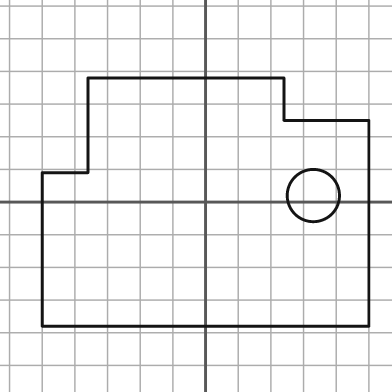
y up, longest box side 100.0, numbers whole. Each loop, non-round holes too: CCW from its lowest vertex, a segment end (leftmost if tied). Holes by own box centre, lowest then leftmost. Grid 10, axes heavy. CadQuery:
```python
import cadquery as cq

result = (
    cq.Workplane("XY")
    .moveTo(-50.0, -38.0)
    .lineTo(50.0, -38.0)
    .lineTo(50.0, 25.0)
    .lineTo(24.0, 25.0)
    .lineTo(24.0, 38.0)
    .lineTo(-36.0, 38.0)
    .lineTo(-36.0, 9.0)
    .lineTo(-50.0, 9.0)
    .close()
    .moveTo(33.0, 2.0)
    .circle(8.0)
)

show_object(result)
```